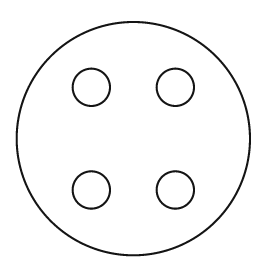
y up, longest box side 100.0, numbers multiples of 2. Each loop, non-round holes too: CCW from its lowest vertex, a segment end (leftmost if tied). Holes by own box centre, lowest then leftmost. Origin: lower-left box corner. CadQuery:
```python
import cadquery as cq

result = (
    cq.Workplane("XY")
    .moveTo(50.0, 50.0)
    .circle(50.0)
    .moveTo(32.0, 28.0)
    .circle(8.0)
    .moveTo(68.0, 28.0)
    .circle(8.0)
    .moveTo(32.0, 72.0)
    .circle(8.0)
    .moveTo(68.0, 72.0)
    .circle(8.0)
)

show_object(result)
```